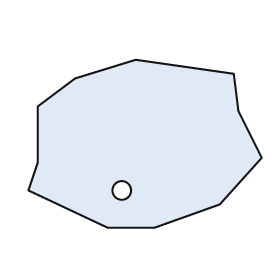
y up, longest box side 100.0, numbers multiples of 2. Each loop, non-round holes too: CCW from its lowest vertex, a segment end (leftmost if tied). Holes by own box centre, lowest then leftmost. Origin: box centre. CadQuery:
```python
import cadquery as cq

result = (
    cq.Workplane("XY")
    .moveTo(-16.0, -36.0)
    .lineTo(4.0, -36.0)
    .lineTo(32.0, -26.0)
    .lineTo(50.0, -6.0)
    .lineTo(40.0, 14.0)
    .lineTo(38.0, 30.0)
    .lineTo(-4.0, 36.0)
    .lineTo(-30.0, 28.0)
    .lineTo(-46.0, 16.0)
    .lineTo(-46.0, -8.0)
    .lineTo(-50.0, -20.0)
    .close()
    .moveTo(-10.0, -20.0)
    .circle(4.0)
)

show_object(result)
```